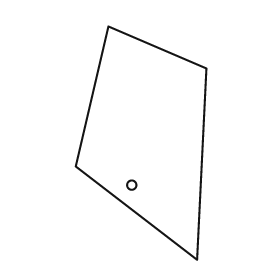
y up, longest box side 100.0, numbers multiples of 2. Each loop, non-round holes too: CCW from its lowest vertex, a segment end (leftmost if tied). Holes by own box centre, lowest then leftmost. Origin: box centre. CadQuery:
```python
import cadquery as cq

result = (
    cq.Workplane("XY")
    .moveTo(24.0, -50.0)
    .lineTo(28.0, 32.0)
    .lineTo(-14.0, 50.0)
    .lineTo(-28.0, -10.0)
    .close()
    .moveTo(-4.0, -18.0)
    .circle(2.0)
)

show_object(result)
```